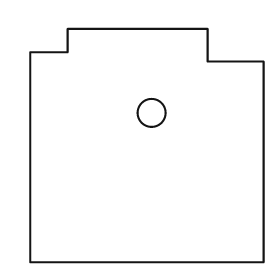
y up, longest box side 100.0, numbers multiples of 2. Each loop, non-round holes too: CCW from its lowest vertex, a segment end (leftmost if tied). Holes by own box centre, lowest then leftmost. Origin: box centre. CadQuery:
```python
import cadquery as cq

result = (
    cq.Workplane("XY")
    .moveTo(-50.0, -50.0)
    .lineTo(50.0, -50.0)
    .lineTo(50.0, 36.0)
    .lineTo(26.0, 36.0)
    .lineTo(26.0, 50.0)
    .lineTo(-34.0, 50.0)
    .lineTo(-34.0, 40.0)
    .lineTo(-50.0, 40.0)
    .close()
    .moveTo(2.0, 14.0)
    .circle(6.0)
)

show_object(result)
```